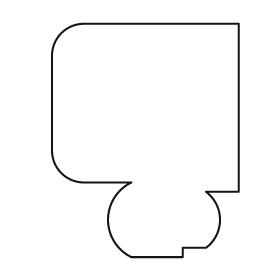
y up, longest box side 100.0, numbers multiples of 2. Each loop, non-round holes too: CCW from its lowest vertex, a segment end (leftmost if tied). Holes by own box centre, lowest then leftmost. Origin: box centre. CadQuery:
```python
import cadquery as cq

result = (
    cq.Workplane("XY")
    .moveTo(-6.0, -50.0)
    .lineTo(16.0, -50.0)
    .lineTo(16.0, -46.0)
    .lineTo(26.0, -46.0)
    .threePointArc((32.0, -34.0), (26.0, -22.0))
    .lineTo(40.0, -22.0)
    .lineTo(40.0, 50.0)
    .lineTo(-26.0, 50.0)
    .threePointArc((-36.0, 46.0), (-40.0, 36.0))
    .lineTo(-40.0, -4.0)
    .threePointArc((-36.0, -14.0), (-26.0, -18.0))
    .lineTo(-6.0, -18.0)
    .threePointArc((-16.0, -34.0), (-6.0, -50.0))
    .close()
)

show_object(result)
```